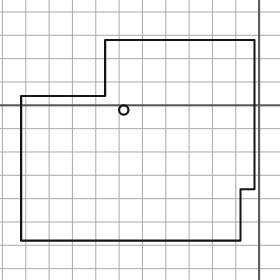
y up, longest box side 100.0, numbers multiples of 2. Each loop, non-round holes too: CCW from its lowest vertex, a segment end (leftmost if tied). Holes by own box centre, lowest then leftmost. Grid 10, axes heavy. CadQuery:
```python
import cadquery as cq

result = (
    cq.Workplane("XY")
    .moveTo(-102.0, -58.0)
    .lineTo(-8.0, -58.0)
    .lineTo(-8.0, -36.0)
    .lineTo(-2.0, -36.0)
    .lineTo(-2.0, 28.0)
    .lineTo(-66.0, 28.0)
    .lineTo(-66.0, 4.0)
    .lineTo(-102.0, 4.0)
    .close()
    .moveTo(-58.0, -2.0)
    .circle(2.0)
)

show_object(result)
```